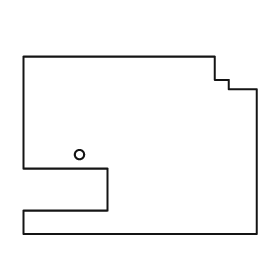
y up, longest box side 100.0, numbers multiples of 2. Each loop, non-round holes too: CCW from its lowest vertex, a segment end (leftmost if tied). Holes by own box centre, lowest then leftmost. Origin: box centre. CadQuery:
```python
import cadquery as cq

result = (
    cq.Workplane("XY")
    .moveTo(-50.0, -38.0)
    .lineTo(50.0, -38.0)
    .lineTo(50.0, 24.0)
    .lineTo(38.0, 24.0)
    .lineTo(38.0, 28.0)
    .lineTo(32.0, 28.0)
    .lineTo(32.0, 38.0)
    .lineTo(-50.0, 38.0)
    .lineTo(-50.0, -10.0)
    .lineTo(-14.0, -10.0)
    .lineTo(-14.0, -28.0)
    .lineTo(-50.0, -28.0)
    .close()
    .moveTo(-26.0, -4.0)
    .circle(2.0)
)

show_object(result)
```